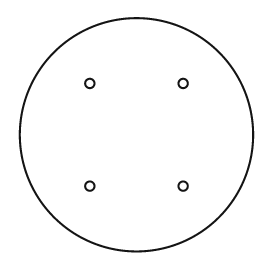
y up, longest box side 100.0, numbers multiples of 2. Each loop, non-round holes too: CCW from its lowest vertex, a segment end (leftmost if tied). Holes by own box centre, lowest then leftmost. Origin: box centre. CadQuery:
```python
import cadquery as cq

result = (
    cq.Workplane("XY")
    .moveTo(0.0, 0.0)
    .circle(50.0)
    .moveTo(-20.0, -22.0)
    .circle(2.0)
    .moveTo(20.0, -22.0)
    .circle(2.0)
    .moveTo(-20.0, 22.0)
    .circle(2.0)
    .moveTo(20.0, 22.0)
    .circle(2.0)
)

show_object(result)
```